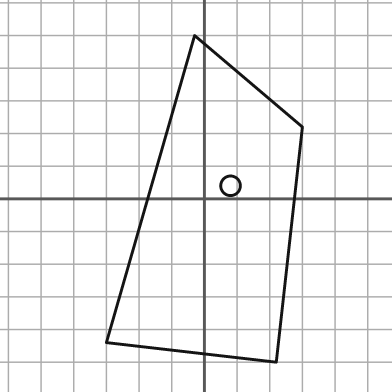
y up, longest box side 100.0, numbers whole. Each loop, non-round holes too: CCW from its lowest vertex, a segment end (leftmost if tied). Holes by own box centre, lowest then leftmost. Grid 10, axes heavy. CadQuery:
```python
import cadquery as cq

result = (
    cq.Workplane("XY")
    .moveTo(22.0, -50.0)
    .lineTo(30.0, 22.0)
    .lineTo(-3.0, 50.0)
    .lineTo(-30.0, -44.0)
    .close()
    .moveTo(8.0, 4.0)
    .circle(3.0)
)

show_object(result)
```